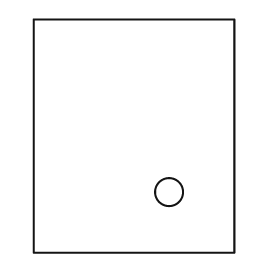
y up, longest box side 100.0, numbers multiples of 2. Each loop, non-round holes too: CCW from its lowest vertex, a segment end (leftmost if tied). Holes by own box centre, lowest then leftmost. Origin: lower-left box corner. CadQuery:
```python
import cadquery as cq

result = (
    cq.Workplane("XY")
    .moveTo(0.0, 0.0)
    .lineTo(86.0, 0.0)
    .lineTo(86.0, 100.0)
    .lineTo(0.0, 100.0)
    .close()
    .moveTo(58.0, 26.0)
    .circle(6.0)
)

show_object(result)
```